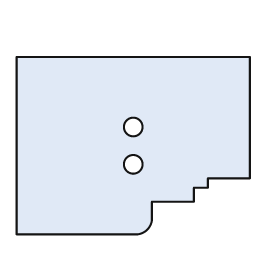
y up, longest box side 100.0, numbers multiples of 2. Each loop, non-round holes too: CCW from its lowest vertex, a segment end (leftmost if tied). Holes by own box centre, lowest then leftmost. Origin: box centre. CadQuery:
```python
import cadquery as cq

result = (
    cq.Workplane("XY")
    .moveTo(-50.0, -38.0)
    .lineTo(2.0, -38.0)
    .threePointArc((6.0, -36.0), (8.0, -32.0))
    .lineTo(8.0, -24.0)
    .lineTo(26.0, -24.0)
    .lineTo(26.0, -18.0)
    .lineTo(32.0, -18.0)
    .lineTo(32.0, -14.0)
    .lineTo(50.0, -14.0)
    .lineTo(50.0, 38.0)
    .lineTo(-50.0, 38.0)
    .close()
    .moveTo(0.0, -8.0)
    .circle(4.0)
    .moveTo(0.0, 8.0)
    .circle(4.0)
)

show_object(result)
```